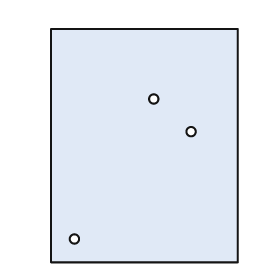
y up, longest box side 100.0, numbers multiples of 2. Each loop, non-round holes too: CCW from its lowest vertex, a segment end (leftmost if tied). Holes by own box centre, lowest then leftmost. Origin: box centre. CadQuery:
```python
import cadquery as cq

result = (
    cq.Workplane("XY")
    .moveTo(-40.0, -50.0)
    .lineTo(40.0, -50.0)
    .lineTo(40.0, 50.0)
    .lineTo(-40.0, 50.0)
    .close()
    .moveTo(-30.0, -40.0)
    .circle(2.0)
    .moveTo(20.0, 6.0)
    .circle(2.0)
    .moveTo(4.0, 20.0)
    .circle(2.0)
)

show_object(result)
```